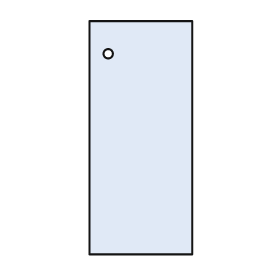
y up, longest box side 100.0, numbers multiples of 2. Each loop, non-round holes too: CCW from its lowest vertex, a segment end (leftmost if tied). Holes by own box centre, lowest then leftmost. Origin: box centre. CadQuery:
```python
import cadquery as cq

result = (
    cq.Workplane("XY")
    .moveTo(-22.0, -50.0)
    .lineTo(22.0, -50.0)
    .lineTo(22.0, 50.0)
    .lineTo(-22.0, 50.0)
    .close()
    .moveTo(-14.0, 36.0)
    .circle(2.0)
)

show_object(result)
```